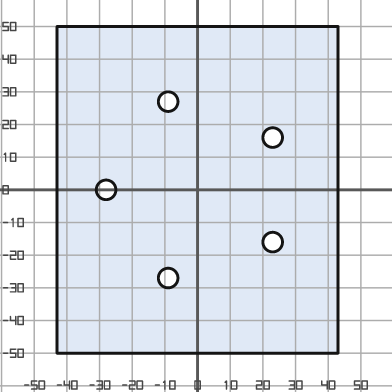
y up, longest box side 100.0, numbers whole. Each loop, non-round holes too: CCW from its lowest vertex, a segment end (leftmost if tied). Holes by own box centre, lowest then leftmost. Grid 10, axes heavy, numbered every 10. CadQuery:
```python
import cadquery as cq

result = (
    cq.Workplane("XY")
    .moveTo(-43.0, -50.0)
    .lineTo(43.0, -50.0)
    .lineTo(43.0, 50.0)
    .lineTo(-43.0, 50.0)
    .close()
    .moveTo(-9.0, -27.0)
    .circle(3.0)
    .moveTo(23.0, -16.0)
    .circle(3.0)
    .moveTo(-28.0, 0.0)
    .circle(3.0)
    .moveTo(23.0, 16.0)
    .circle(3.0)
    .moveTo(-9.0, 27.0)
    .circle(3.0)
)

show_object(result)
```